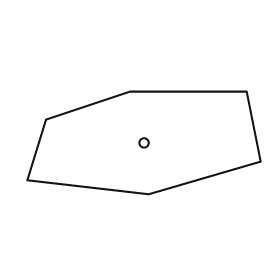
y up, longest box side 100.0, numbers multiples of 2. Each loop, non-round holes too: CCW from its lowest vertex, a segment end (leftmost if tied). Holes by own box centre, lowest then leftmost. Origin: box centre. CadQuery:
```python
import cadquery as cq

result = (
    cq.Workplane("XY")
    .moveTo(2.0, -22.0)
    .lineTo(50.0, -8.0)
    .lineTo(44.0, 22.0)
    .lineTo(-6.0, 22.0)
    .lineTo(-42.0, 10.0)
    .lineTo(-50.0, -16.0)
    .close()
    .moveTo(0.0, 0.0)
    .circle(2.0)
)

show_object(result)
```